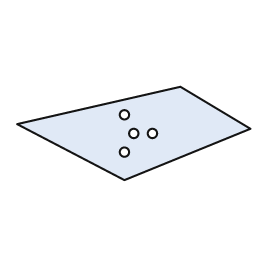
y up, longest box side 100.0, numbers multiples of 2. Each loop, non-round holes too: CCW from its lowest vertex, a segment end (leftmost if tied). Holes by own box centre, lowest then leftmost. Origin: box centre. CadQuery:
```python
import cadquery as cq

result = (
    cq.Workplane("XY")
    .moveTo(-4.0, -20.0)
    .lineTo(50.0, 2.0)
    .lineTo(20.0, 20.0)
    .lineTo(-50.0, 4.0)
    .close()
    .moveTo(-4.0, -8.0)
    .circle(2.0)
    .moveTo(0.0, 0.0)
    .circle(2.0)
    .moveTo(8.0, 0.0)
    .circle(2.0)
    .moveTo(-4.0, 8.0)
    .circle(2.0)
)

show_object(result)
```